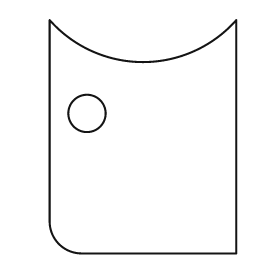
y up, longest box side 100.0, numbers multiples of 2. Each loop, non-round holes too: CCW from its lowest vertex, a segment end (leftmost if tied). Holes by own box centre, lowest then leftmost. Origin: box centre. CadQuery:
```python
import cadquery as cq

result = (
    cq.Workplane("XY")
    .moveTo(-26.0, -50.0)
    .lineTo(40.0, -50.0)
    .lineTo(40.0, 50.0)
    .threePointArc((0.0, 32.0), (-40.0, 50.0))
    .lineTo(-40.0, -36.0)
    .threePointArc((-36.0, -46.0), (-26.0, -50.0))
    .close()
    .moveTo(-24.0, 10.0)
    .circle(8.0)
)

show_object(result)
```